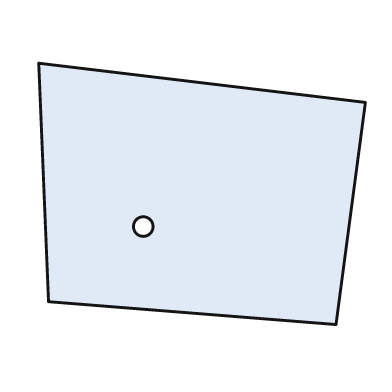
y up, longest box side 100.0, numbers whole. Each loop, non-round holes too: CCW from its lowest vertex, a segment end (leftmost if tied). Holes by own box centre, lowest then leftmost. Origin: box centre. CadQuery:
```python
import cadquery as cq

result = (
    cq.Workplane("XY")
    .moveTo(41.0, -40.0)
    .lineTo(50.0, 28.0)
    .lineTo(-50.0, 40.0)
    .lineTo(-47.0, -33.0)
    .close()
    .moveTo(-18.0, -10.0)
    .circle(3.0)
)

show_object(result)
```